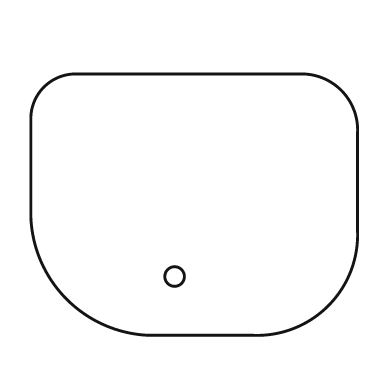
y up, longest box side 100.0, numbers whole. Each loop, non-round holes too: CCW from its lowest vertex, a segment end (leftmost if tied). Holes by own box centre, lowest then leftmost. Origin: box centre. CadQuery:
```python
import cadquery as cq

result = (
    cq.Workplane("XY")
    .moveTo(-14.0, -40.0)
    .lineTo(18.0, -40.0)
    .threePointArc((41.0, -31.0), (50.0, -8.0))
    .lineTo(50.0, 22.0)
    .threePointArc((45.0, 35.0), (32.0, 40.0))
    .lineTo(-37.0, 40.0)
    .threePointArc((-46.0, 36.0), (-50.0, 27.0))
    .lineTo(-50.0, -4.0)
    .threePointArc((-39.0, -29.0), (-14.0, -40.0))
    .close()
    .moveTo(-6.0, -22.0)
    .circle(3.0)
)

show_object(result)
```